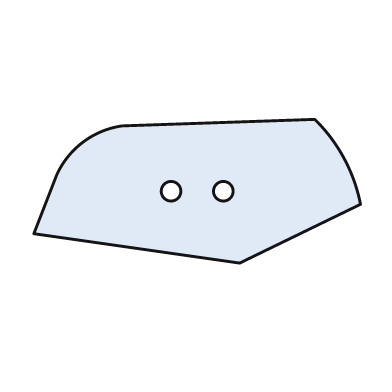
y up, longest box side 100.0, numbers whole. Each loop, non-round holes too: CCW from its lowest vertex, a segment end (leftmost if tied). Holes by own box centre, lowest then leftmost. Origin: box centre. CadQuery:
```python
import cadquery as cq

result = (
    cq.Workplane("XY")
    .moveTo(13.0, -22.0)
    .lineTo(50.0, -4.0)
    .threePointArc((45.0, 10.0), (36.0, 22.0))
    .lineTo(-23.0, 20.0)
    .threePointArc((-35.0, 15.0), (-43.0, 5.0))
    .lineTo(-50.0, -13.0)
    .close()
    .moveTo(-8.0, 0.0)
    .circle(3.0)
    .moveTo(8.0, 0.0)
    .circle(3.0)
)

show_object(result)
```